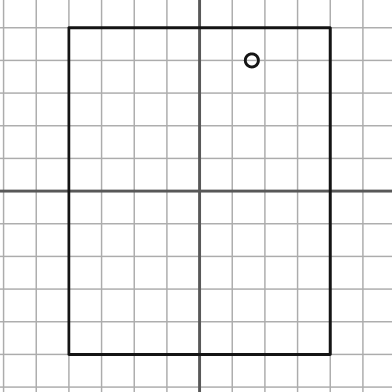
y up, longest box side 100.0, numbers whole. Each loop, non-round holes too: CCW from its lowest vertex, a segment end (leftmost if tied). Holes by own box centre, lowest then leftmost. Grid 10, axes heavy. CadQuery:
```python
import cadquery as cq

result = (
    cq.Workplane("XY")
    .moveTo(-40.0, -50.0)
    .lineTo(40.0, -50.0)
    .lineTo(40.0, 50.0)
    .lineTo(-40.0, 50.0)
    .close()
    .moveTo(16.0, 40.0)
    .circle(2.0)
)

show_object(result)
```